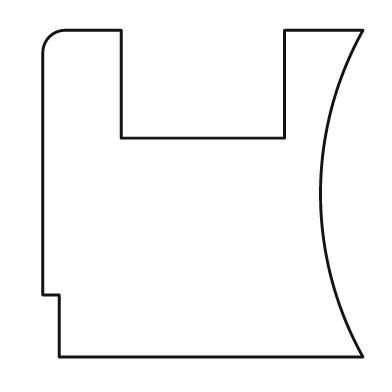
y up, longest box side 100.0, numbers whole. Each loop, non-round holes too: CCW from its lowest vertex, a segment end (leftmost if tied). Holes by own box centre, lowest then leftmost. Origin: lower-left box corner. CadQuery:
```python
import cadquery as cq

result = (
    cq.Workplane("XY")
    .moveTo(5.0, 0.0)
    .lineTo(98.0, 0.0)
    .threePointArc((85.0, 50.0), (98.0, 100.0))
    .lineTo(74.0, 100.0)
    .lineTo(74.0, 67.0)
    .lineTo(24.0, 67.0)
    .lineTo(24.0, 100.0)
    .lineTo(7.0, 100.0)
    .threePointArc((2.0, 98.0), (0.0, 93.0))
    .lineTo(0.0, 19.0)
    .lineTo(5.0, 19.0)
    .close()
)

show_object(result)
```